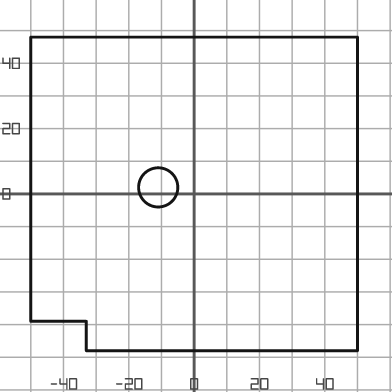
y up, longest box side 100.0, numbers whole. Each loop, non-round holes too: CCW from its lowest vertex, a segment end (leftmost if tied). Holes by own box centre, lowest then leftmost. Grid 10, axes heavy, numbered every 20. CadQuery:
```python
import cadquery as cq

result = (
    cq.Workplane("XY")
    .moveTo(-33.0, -48.0)
    .lineTo(50.0, -48.0)
    .lineTo(50.0, 48.0)
    .lineTo(-50.0, 48.0)
    .lineTo(-50.0, -39.0)
    .lineTo(-33.0, -39.0)
    .close()
    .moveTo(-11.0, 2.0)
    .circle(6.0)
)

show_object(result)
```